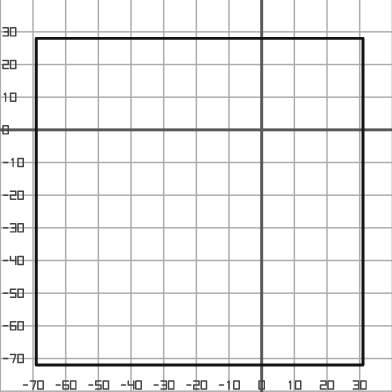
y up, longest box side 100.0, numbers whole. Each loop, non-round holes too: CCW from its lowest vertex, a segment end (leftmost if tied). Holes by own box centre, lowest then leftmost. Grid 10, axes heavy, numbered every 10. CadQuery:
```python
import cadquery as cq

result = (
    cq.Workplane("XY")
    .moveTo(-69.0, -72.0)
    .lineTo(31.0, -72.0)
    .lineTo(31.0, 28.0)
    .lineTo(-69.0, 28.0)
    .close()
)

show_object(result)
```